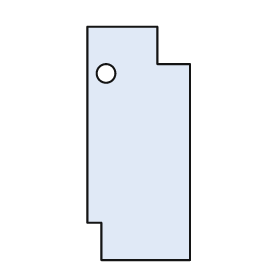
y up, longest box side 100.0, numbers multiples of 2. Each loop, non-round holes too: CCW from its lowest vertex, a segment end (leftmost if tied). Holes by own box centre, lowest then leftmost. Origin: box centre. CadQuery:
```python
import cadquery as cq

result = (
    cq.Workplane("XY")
    .moveTo(-16.0, -50.0)
    .lineTo(22.0, -50.0)
    .lineTo(22.0, 34.0)
    .lineTo(8.0, 34.0)
    .lineTo(8.0, 50.0)
    .lineTo(-22.0, 50.0)
    .lineTo(-22.0, -34.0)
    .lineTo(-16.0, -34.0)
    .close()
    .moveTo(-14.0, 30.0)
    .circle(4.0)
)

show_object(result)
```